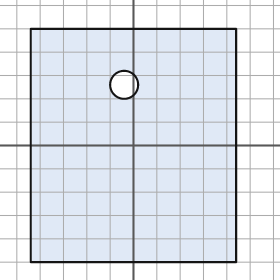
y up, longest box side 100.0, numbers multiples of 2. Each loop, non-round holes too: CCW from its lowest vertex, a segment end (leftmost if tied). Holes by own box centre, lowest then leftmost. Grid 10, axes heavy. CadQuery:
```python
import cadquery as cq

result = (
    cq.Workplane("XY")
    .moveTo(-44.0, -50.0)
    .lineTo(44.0, -50.0)
    .lineTo(44.0, 50.0)
    .lineTo(-44.0, 50.0)
    .close()
    .moveTo(-4.0, 26.0)
    .circle(6.0)
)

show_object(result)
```